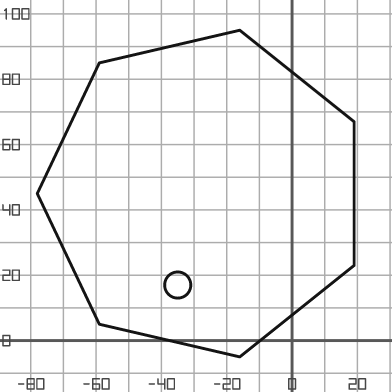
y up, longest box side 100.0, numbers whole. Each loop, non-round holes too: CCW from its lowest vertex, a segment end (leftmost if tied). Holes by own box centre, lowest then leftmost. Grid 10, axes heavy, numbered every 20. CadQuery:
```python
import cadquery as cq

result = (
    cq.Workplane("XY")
    .moveTo(-16.0, -5.0)
    .lineTo(19.0, 23.0)
    .lineTo(19.0, 67.0)
    .lineTo(-16.0, 95.0)
    .lineTo(-59.0, 85.0)
    .lineTo(-78.0, 45.0)
    .lineTo(-59.0, 5.0)
    .close()
    .moveTo(-35.0, 17.0)
    .circle(4.0)
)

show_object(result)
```